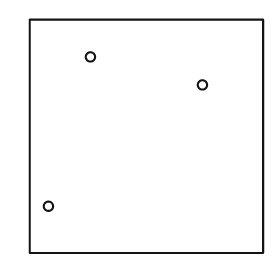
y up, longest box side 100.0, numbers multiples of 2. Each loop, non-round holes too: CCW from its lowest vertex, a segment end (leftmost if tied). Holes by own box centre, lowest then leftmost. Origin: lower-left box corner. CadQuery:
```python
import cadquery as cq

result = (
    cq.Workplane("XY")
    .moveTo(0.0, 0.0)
    .lineTo(100.0, 0.0)
    .lineTo(100.0, 100.0)
    .lineTo(0.0, 100.0)
    .close()
    .moveTo(8.0, 20.0)
    .circle(2.0)
    .moveTo(74.0, 72.0)
    .circle(2.0)
    .moveTo(26.0, 84.0)
    .circle(2.0)
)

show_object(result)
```